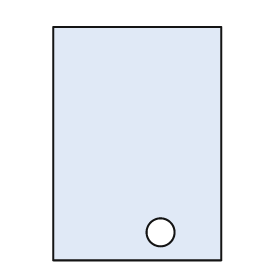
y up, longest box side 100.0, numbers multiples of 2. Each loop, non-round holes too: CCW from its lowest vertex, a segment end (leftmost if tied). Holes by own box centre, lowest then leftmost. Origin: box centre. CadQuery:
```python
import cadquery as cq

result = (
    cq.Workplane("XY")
    .moveTo(-36.0, -50.0)
    .lineTo(36.0, -50.0)
    .lineTo(36.0, 50.0)
    .lineTo(-36.0, 50.0)
    .close()
    .moveTo(10.0, -38.0)
    .circle(6.0)
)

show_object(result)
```